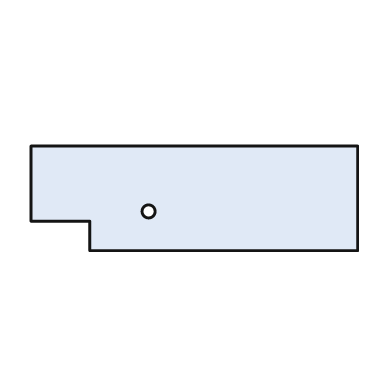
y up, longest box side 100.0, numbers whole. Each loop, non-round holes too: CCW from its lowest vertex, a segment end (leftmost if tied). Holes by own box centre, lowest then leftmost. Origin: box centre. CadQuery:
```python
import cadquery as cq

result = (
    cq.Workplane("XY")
    .moveTo(-32.0, -16.0)
    .lineTo(50.0, -16.0)
    .lineTo(50.0, 16.0)
    .lineTo(-50.0, 16.0)
    .lineTo(-50.0, -7.0)
    .lineTo(-32.0, -7.0)
    .close()
    .moveTo(-14.0, -4.0)
    .circle(2.0)
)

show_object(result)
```